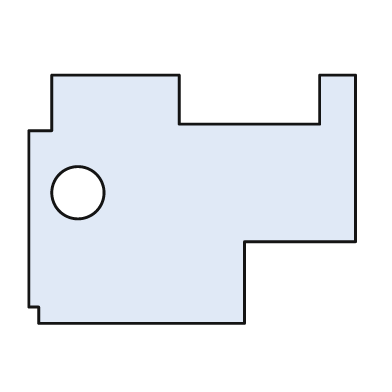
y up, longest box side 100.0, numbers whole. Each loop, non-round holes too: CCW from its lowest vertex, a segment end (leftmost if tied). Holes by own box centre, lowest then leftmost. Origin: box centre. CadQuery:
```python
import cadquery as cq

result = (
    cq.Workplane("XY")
    .moveTo(-47.0, -38.0)
    .lineTo(16.0, -38.0)
    .lineTo(16.0, -13.0)
    .lineTo(50.0, -13.0)
    .lineTo(50.0, 38.0)
    .lineTo(39.0, 38.0)
    .lineTo(39.0, 23.0)
    .lineTo(-4.0, 23.0)
    .lineTo(-4.0, 38.0)
    .lineTo(-43.0, 38.0)
    .lineTo(-43.0, 21.0)
    .lineTo(-50.0, 21.0)
    .lineTo(-50.0, -33.0)
    .lineTo(-47.0, -33.0)
    .close()
    .moveTo(-35.0, 2.0)
    .circle(8.0)
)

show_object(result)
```